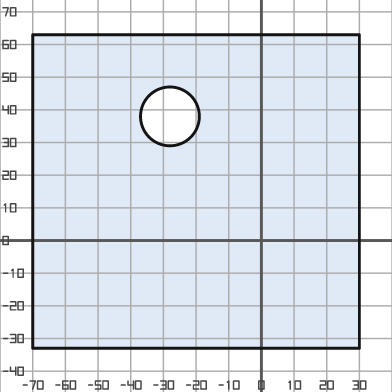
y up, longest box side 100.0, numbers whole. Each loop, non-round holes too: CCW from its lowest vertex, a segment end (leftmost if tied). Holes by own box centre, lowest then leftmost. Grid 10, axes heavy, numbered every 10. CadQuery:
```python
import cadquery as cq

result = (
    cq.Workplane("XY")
    .moveTo(-70.0, -33.0)
    .lineTo(30.0, -33.0)
    .lineTo(30.0, 63.0)
    .lineTo(-70.0, 63.0)
    .close()
    .moveTo(-28.0, 38.0)
    .circle(9.0)
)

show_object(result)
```